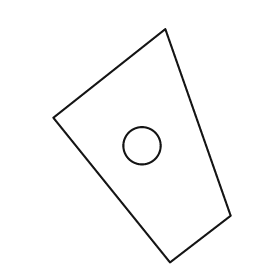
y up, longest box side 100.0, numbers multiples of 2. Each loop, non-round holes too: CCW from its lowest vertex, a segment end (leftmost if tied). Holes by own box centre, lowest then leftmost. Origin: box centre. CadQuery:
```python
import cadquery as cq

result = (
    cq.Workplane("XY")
    .moveTo(12.0, -50.0)
    .lineTo(38.0, -30.0)
    .lineTo(10.0, 50.0)
    .lineTo(-38.0, 12.0)
    .close()
    .moveTo(0.0, 0.0)
    .circle(8.0)
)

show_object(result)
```